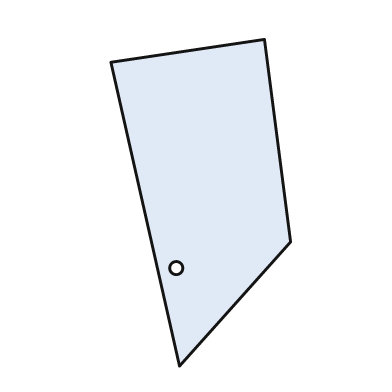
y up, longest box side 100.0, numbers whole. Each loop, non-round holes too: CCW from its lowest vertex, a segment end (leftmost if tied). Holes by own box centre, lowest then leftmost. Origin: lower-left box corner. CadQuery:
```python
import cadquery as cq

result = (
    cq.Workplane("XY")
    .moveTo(21.0, 0.0)
    .lineTo(55.0, 38.0)
    .lineTo(47.0, 100.0)
    .lineTo(0.0, 93.0)
    .close()
    .moveTo(20.0, 30.0)
    .circle(2.0)
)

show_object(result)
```